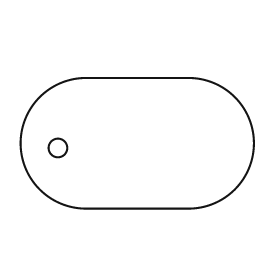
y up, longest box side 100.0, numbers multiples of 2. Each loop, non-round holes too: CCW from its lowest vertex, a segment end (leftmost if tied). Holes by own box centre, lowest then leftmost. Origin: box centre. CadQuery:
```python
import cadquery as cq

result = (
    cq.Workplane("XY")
    .moveTo(-22.0, -28.0)
    .lineTo(22.0, -28.0)
    .threePointArc((50.0, 0.0), (22.0, 28.0))
    .lineTo(-22.0, 28.0)
    .threePointArc((-50.0, 0.0), (-22.0, -28.0))
    .close()
    .moveTo(-34.0, -2.0)
    .circle(4.0)
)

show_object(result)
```